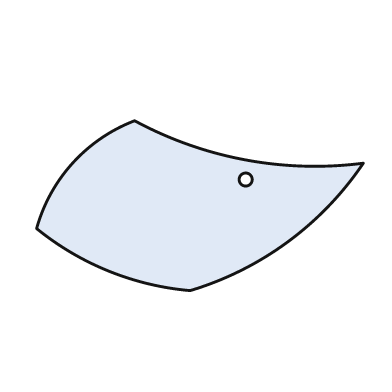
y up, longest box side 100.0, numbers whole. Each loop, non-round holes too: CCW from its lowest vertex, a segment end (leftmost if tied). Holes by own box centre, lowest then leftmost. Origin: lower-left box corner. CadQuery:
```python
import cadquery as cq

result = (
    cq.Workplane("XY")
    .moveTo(47.0, 0.0)
    .threePointArc((77.0, 15.0), (100.0, 39.0))
    .threePointArc((64.0, 40.0), (30.0, 52.0))
    .threePointArc((11.0, 39.0), (0.0, 19.0))
    .threePointArc((22.0, 6.0), (47.0, 0.0))
    .close()
    .moveTo(64.0, 34.0)
    .circle(2.0)
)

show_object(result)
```